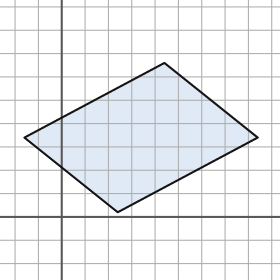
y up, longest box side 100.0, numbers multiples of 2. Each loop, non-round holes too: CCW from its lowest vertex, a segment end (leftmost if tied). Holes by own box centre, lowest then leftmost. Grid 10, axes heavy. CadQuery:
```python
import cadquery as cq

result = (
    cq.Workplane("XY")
    .moveTo(24.0, 2.0)
    .lineTo(84.0, 34.0)
    .lineTo(44.0, 66.0)
    .lineTo(-16.0, 34.0)
    .close()
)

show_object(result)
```